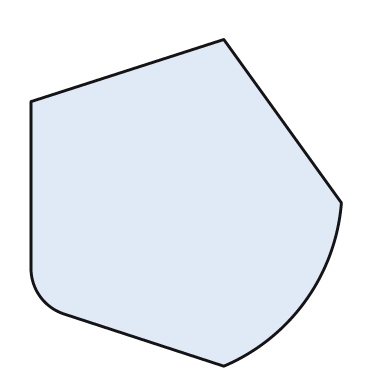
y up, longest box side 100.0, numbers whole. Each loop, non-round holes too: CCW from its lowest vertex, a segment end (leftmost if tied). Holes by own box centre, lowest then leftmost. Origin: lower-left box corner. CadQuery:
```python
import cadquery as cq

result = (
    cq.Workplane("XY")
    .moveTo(59.0, 0.0)
    .threePointArc((84.0, 20.0), (95.0, 50.0))
    .lineTo(59.0, 100.0)
    .lineTo(0.0, 81.0)
    .lineTo(0.0, 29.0)
    .threePointArc((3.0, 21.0), (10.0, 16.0))
    .close()
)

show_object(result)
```